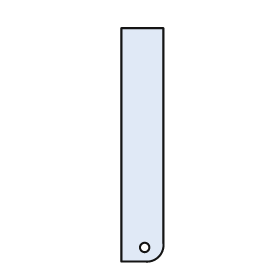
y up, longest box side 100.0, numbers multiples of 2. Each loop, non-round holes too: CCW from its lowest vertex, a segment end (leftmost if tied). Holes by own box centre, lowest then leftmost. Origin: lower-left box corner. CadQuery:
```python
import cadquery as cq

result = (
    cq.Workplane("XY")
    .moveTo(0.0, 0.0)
    .lineTo(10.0, 0.0)
    .threePointArc((16.0, 2.0), (18.0, 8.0))
    .lineTo(18.0, 100.0)
    .lineTo(0.0, 100.0)
    .close()
    .moveTo(10.0, 6.0)
    .circle(2.0)
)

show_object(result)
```